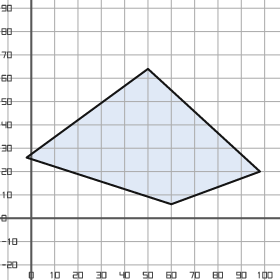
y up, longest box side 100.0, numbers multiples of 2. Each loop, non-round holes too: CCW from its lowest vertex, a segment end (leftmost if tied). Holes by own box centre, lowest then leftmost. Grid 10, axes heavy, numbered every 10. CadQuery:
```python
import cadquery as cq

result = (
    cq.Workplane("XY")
    .moveTo(60.0, 6.0)
    .lineTo(98.0, 20.0)
    .lineTo(50.0, 64.0)
    .lineTo(-2.0, 26.0)
    .close()
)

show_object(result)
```